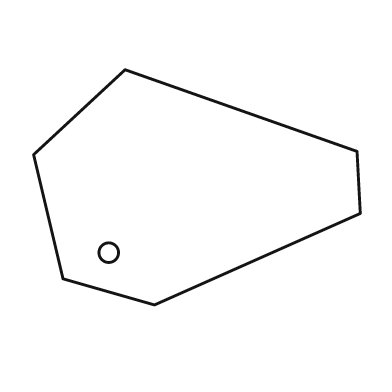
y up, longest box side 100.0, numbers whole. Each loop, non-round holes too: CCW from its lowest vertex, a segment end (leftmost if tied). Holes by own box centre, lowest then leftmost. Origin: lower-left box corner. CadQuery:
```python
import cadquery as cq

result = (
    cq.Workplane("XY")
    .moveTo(37.0, 0.0)
    .lineTo(100.0, 28.0)
    .lineTo(99.0, 47.0)
    .lineTo(28.0, 72.0)
    .lineTo(0.0, 46.0)
    .lineTo(9.0, 8.0)
    .close()
    .moveTo(23.0, 16.0)
    .circle(3.0)
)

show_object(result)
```